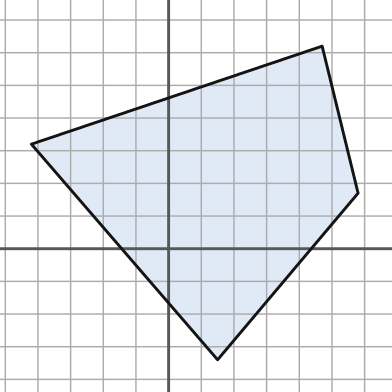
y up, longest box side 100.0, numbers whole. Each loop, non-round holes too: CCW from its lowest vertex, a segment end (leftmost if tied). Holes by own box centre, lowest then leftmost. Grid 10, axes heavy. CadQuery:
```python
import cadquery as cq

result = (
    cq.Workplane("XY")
    .moveTo(15.0, -34.0)
    .lineTo(58.0, 17.0)
    .lineTo(47.0, 62.0)
    .lineTo(-42.0, 32.0)
    .close()
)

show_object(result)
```